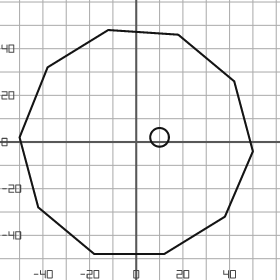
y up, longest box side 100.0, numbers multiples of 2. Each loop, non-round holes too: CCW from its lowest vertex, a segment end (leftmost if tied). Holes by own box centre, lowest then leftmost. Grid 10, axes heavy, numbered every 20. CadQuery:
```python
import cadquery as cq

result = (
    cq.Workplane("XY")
    .moveTo(-18.0, -48.0)
    .lineTo(12.0, -48.0)
    .lineTo(38.0, -32.0)
    .lineTo(50.0, -4.0)
    .lineTo(42.0, 26.0)
    .lineTo(18.0, 46.0)
    .lineTo(-12.0, 48.0)
    .lineTo(-38.0, 32.0)
    .lineTo(-50.0, 2.0)
    .lineTo(-42.0, -28.0)
    .close()
    .moveTo(10.0, 2.0)
    .circle(4.0)
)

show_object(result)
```